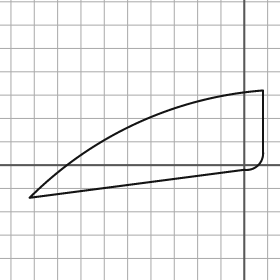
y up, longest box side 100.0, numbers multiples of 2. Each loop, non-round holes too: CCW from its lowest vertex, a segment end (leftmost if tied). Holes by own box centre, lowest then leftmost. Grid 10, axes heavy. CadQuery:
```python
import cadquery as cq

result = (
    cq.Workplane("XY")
    .moveTo(-92.0, -14.0)
    .lineTo(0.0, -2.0)
    .threePointArc((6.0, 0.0), (8.0, 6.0))
    .lineTo(8.0, 32.0)
    .threePointArc((-46.0, 18.0), (-92.0, -14.0))
    .close()
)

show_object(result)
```